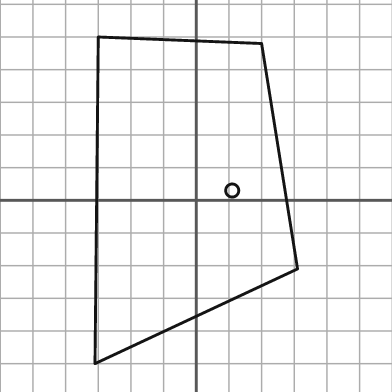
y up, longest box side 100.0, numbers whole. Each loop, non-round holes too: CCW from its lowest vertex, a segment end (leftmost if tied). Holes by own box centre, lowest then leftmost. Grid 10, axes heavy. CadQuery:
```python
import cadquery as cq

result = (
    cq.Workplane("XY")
    .moveTo(-31.0, -50.0)
    .lineTo(31.0, -21.0)
    .lineTo(20.0, 48.0)
    .lineTo(-30.0, 50.0)
    .close()
    .moveTo(11.0, 3.0)
    .circle(2.0)
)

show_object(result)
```